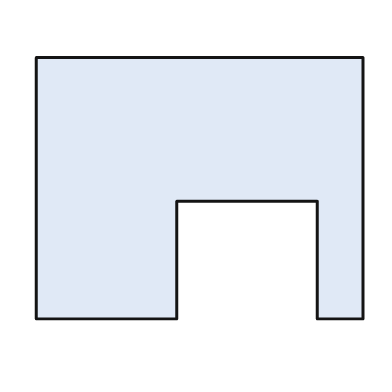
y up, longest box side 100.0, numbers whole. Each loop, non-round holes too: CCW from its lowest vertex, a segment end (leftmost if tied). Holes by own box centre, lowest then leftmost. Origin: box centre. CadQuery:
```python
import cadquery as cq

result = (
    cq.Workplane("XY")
    .moveTo(-50.0, -40.0)
    .lineTo(-7.0, -40.0)
    .lineTo(-7.0, -4.0)
    .lineTo(36.0, -4.0)
    .lineTo(36.0, -40.0)
    .lineTo(50.0, -40.0)
    .lineTo(50.0, 40.0)
    .lineTo(-50.0, 40.0)
    .close()
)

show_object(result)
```